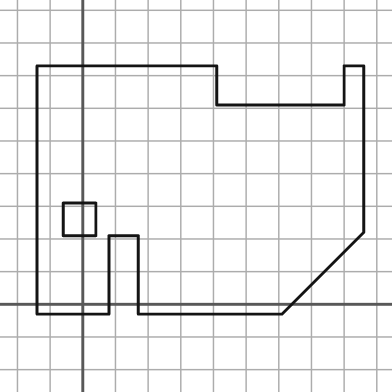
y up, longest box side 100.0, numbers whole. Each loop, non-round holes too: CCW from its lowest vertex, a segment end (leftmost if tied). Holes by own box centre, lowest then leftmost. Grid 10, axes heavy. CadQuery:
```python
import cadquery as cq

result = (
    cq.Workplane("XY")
    .moveTo(-14.0, -3.0)
    .lineTo(8.0, -3.0)
    .lineTo(8.0, 21.0)
    .lineTo(17.0, 21.0)
    .lineTo(17.0, -3.0)
    .lineTo(61.0, -3.0)
    .lineTo(86.0, 22.0)
    .lineTo(86.0, 73.0)
    .lineTo(80.0, 73.0)
    .lineTo(80.0, 61.0)
    .lineTo(41.0, 61.0)
    .lineTo(41.0, 73.0)
    .lineTo(-14.0, 73.0)
    .close()
    .moveTo(-6.0, 21.0)
    .lineTo(4.0, 21.0)
    .lineTo(4.0, 31.0)
    .lineTo(-6.0, 31.0)
    .close()
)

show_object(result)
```